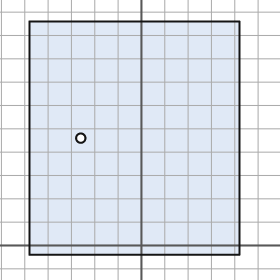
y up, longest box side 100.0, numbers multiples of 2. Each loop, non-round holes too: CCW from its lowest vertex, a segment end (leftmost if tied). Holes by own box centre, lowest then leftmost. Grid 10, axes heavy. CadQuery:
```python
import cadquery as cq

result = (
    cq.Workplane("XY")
    .moveTo(-48.0, -4.0)
    .lineTo(42.0, -4.0)
    .lineTo(42.0, 96.0)
    .lineTo(-48.0, 96.0)
    .close()
    .moveTo(-26.0, 46.0)
    .circle(2.0)
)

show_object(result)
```